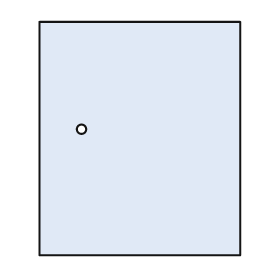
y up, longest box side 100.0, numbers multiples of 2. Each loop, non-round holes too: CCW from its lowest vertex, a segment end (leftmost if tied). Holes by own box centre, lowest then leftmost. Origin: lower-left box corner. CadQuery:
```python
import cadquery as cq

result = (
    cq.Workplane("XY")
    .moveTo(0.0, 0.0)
    .lineTo(86.0, 0.0)
    .lineTo(86.0, 100.0)
    .lineTo(0.0, 100.0)
    .close()
    .moveTo(18.0, 54.0)
    .circle(2.0)
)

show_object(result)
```